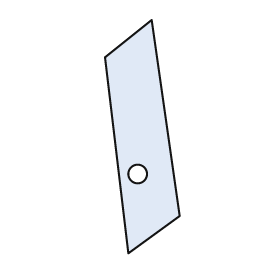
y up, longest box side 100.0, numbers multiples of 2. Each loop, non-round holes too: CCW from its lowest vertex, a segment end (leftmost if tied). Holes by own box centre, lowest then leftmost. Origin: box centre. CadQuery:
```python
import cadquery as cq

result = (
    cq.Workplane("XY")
    .moveTo(-6.0, -50.0)
    .lineTo(16.0, -34.0)
    .lineTo(4.0, 50.0)
    .lineTo(-16.0, 34.0)
    .close()
    .moveTo(-2.0, -16.0)
    .circle(4.0)
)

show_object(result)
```